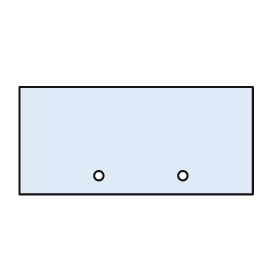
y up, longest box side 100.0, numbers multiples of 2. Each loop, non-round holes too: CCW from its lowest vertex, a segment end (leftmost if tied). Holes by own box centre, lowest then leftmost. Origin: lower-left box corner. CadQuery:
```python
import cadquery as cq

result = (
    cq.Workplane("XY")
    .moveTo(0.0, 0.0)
    .lineTo(100.0, 0.0)
    .lineTo(100.0, 46.0)
    .lineTo(0.0, 46.0)
    .close()
    .moveTo(34.0, 8.0)
    .circle(2.0)
    .moveTo(70.0, 8.0)
    .circle(2.0)
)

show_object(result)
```